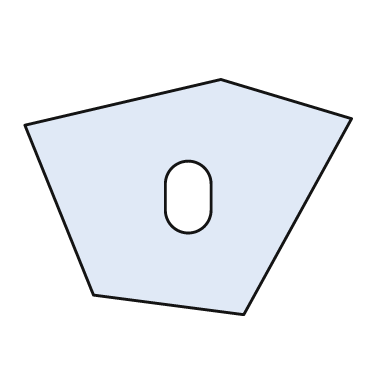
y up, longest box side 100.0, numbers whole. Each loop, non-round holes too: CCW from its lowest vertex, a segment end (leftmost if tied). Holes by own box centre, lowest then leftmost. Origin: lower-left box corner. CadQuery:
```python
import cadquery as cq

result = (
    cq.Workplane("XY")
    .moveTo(67.0, 0.0)
    .lineTo(100.0, 60.0)
    .lineTo(60.0, 72.0)
    .lineTo(0.0, 58.0)
    .lineTo(21.0, 6.0)
    .close()
    .moveTo(43.0, 32.0)
    .threePointArc((50.0, 25.0), (57.0, 32.0))
    .lineTo(57.0, 40.0)
    .threePointArc((50.0, 47.0), (43.0, 40.0))
    .close()
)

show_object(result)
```